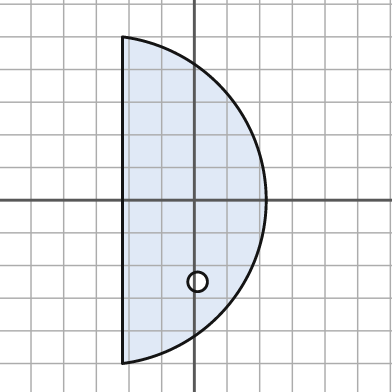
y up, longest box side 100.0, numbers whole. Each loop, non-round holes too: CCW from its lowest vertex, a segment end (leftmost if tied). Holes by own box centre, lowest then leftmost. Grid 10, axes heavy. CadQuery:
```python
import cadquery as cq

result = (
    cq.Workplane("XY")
    .moveTo(-22.0, -50.0)
    .threePointArc((22.0, 0.0), (-22.0, 50.0))
    .close()
    .moveTo(1.0, -25.0)
    .circle(3.0)
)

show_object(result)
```